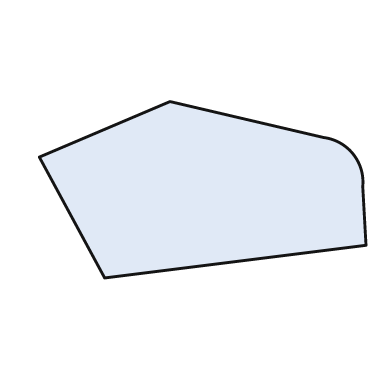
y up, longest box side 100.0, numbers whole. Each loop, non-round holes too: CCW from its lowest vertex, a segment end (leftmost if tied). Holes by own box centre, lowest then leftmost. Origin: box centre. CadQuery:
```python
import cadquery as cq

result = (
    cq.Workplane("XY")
    .moveTo(-30.0, -27.0)
    .lineTo(50.0, -17.0)
    .lineTo(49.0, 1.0)
    .threePointArc((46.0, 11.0), (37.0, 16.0))
    .lineTo(-10.0, 27.0)
    .lineTo(-50.0, 10.0)
    .close()
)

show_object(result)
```